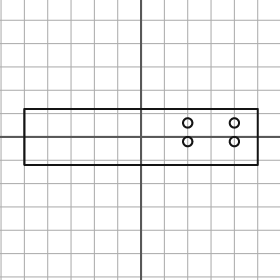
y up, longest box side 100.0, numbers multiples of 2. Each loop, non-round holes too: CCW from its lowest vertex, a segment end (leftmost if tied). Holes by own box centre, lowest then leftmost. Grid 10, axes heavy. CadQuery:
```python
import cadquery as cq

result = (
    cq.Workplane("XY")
    .moveTo(-50.0, -12.0)
    .lineTo(50.0, -12.0)
    .lineTo(50.0, 12.0)
    .lineTo(-50.0, 12.0)
    .close()
    .moveTo(20.0, -2.0)
    .circle(2.0)
    .moveTo(40.0, -2.0)
    .circle(2.0)
    .moveTo(20.0, 6.0)
    .circle(2.0)
    .moveTo(40.0, 6.0)
    .circle(2.0)
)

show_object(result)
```